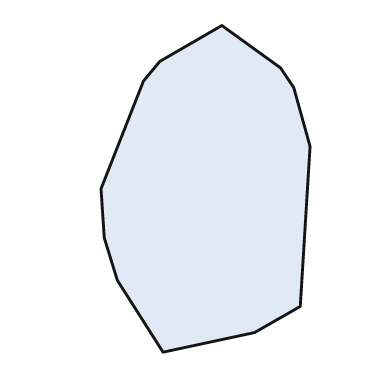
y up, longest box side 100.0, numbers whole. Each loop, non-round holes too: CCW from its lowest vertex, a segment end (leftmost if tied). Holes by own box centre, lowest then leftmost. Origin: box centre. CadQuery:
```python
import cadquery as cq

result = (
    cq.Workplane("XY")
    .moveTo(-13.0, -50.0)
    .lineTo(15.0, -44.0)
    .lineTo(29.0, -36.0)
    .lineTo(32.0, 13.0)
    .lineTo(27.0, 31.0)
    .lineTo(23.0, 37.0)
    .lineTo(5.0, 50.0)
    .lineTo(-14.0, 39.0)
    .lineTo(-19.0, 33.0)
    .lineTo(-32.0, 0.0)
    .lineTo(-31.0, -15.0)
    .lineTo(-27.0, -28.0)
    .close()
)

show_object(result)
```